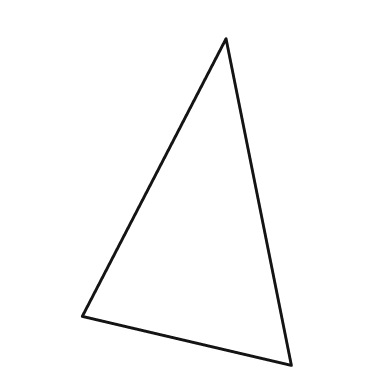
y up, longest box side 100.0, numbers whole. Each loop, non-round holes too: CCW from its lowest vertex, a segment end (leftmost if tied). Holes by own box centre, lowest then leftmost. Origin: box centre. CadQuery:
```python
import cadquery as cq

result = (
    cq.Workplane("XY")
    .moveTo(32.0, -50.0)
    .lineTo(12.0, 50.0)
    .lineTo(-32.0, -35.0)
    .close()
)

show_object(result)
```